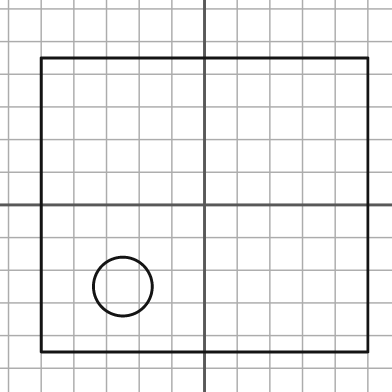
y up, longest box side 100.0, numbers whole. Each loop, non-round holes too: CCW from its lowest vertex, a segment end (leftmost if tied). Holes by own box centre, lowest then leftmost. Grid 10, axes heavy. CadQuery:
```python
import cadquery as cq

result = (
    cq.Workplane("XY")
    .moveTo(-50.0, -45.0)
    .lineTo(50.0, -45.0)
    .lineTo(50.0, 45.0)
    .lineTo(-50.0, 45.0)
    .close()
    .moveTo(-25.0, -25.0)
    .circle(9.0)
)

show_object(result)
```